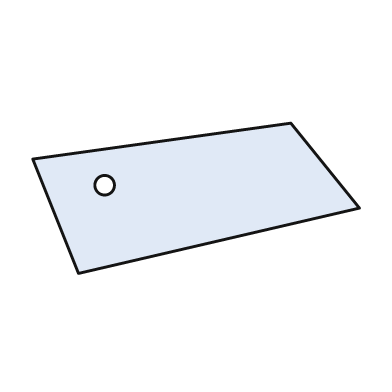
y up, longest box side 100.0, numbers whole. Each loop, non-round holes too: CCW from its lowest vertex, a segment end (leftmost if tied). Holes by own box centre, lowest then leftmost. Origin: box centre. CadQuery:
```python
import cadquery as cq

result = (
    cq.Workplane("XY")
    .moveTo(-36.0, -23.0)
    .lineTo(50.0, -3.0)
    .lineTo(29.0, 23.0)
    .lineTo(-50.0, 12.0)
    .close()
    .moveTo(-28.0, 4.0)
    .circle(3.0)
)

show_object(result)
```